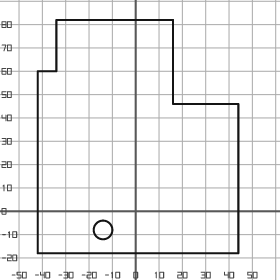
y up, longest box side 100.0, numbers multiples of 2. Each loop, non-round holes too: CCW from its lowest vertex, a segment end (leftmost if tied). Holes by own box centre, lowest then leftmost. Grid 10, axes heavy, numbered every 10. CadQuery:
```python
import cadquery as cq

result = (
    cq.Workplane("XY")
    .moveTo(-42.0, -18.0)
    .lineTo(44.0, -18.0)
    .lineTo(44.0, 46.0)
    .lineTo(16.0, 46.0)
    .lineTo(16.0, 82.0)
    .lineTo(-34.0, 82.0)
    .lineTo(-34.0, 60.0)
    .lineTo(-42.0, 60.0)
    .close()
    .moveTo(-14.0, -8.0)
    .circle(4.0)
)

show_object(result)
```